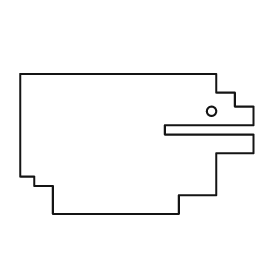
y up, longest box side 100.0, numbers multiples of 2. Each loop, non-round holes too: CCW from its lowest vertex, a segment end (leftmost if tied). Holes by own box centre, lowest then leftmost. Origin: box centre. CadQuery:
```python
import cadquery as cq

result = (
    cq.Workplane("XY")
    .moveTo(-36.0, -30.0)
    .lineTo(18.0, -30.0)
    .lineTo(18.0, -22.0)
    .lineTo(34.0, -22.0)
    .lineTo(34.0, -4.0)
    .lineTo(50.0, -4.0)
    .lineTo(50.0, 4.0)
    .lineTo(12.0, 4.0)
    .lineTo(12.0, 8.0)
    .lineTo(50.0, 8.0)
    .lineTo(50.0, 16.0)
    .lineTo(42.0, 16.0)
    .lineTo(42.0, 22.0)
    .lineTo(34.0, 22.0)
    .lineTo(34.0, 30.0)
    .lineTo(-50.0, 30.0)
    .lineTo(-50.0, -14.0)
    .lineTo(-44.0, -14.0)
    .lineTo(-44.0, -18.0)
    .lineTo(-36.0, -18.0)
    .close()
    .moveTo(32.0, 14.0)
    .circle(2.0)
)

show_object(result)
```